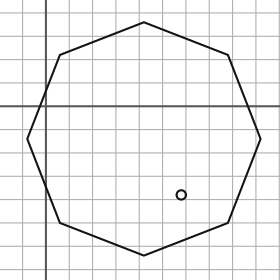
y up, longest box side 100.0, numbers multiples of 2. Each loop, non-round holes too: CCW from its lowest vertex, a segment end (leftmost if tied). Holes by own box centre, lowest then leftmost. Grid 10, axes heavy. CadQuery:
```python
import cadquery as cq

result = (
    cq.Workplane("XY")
    .moveTo(42.0, -64.0)
    .lineTo(78.0, -50.0)
    .lineTo(92.0, -14.0)
    .lineTo(78.0, 22.0)
    .lineTo(42.0, 36.0)
    .lineTo(6.0, 22.0)
    .lineTo(-8.0, -14.0)
    .lineTo(6.0, -50.0)
    .close()
    .moveTo(58.0, -38.0)
    .circle(2.0)
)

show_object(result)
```